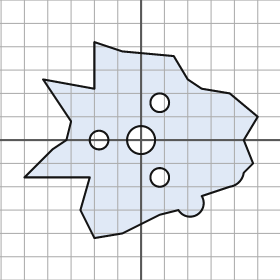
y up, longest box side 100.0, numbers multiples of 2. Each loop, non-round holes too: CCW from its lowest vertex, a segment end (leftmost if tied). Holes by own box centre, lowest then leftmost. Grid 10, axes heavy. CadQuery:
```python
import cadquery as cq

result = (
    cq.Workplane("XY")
    .moveTo(-20.0, -42.0)
    .lineTo(-8.0, -40.0)
    .lineTo(8.0, -32.0)
    .lineTo(16.0, -30.0)
    .threePointArc((24.0, -32.0), (26.0, -24.0))
    .lineTo(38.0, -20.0)
    .threePointArc((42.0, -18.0), (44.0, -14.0))
    .lineTo(48.0, -10.0)
    .lineTo(44.0, 0.0)
    .lineTo(50.0, 10.0)
    .lineTo(38.0, 20.0)
    .lineTo(26.0, 22.0)
    .lineTo(20.0, 26.0)
    .lineTo(14.0, 36.0)
    .lineTo(-8.0, 38.0)
    .lineTo(-20.0, 42.0)
    .lineTo(-20.0, 22.0)
    .lineTo(-42.0, 26.0)
    .lineTo(-30.0, 8.0)
    .lineTo(-32.0, 0.0)
    .lineTo(-38.0, -4.0)
    .lineTo(-50.0, -16.0)
    .lineTo(-22.0, -16.0)
    .lineTo(-26.0, -30.0)
    .close()
    .moveTo(8.0, -16.0)
    .circle(4.0)
    .moveTo(-18.0, 0.0)
    .circle(4.0)
    .moveTo(0.0, 0.0)
    .circle(6.0)
    .moveTo(8.0, 16.0)
    .circle(4.0)
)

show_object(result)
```